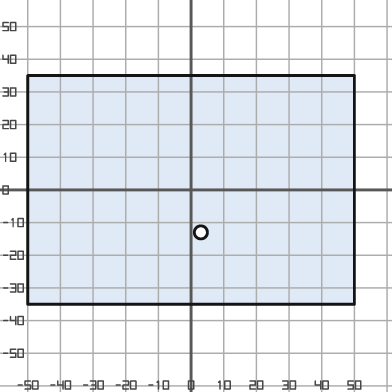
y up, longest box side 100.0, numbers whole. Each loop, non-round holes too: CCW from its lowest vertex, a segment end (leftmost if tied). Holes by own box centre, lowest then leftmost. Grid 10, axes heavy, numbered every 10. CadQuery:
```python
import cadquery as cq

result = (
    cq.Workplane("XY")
    .moveTo(-50.0, -35.0)
    .lineTo(50.0, -35.0)
    .lineTo(50.0, 35.0)
    .lineTo(-50.0, 35.0)
    .close()
    .moveTo(3.0, -13.0)
    .circle(2.0)
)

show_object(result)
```